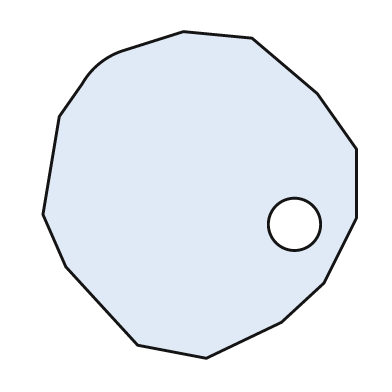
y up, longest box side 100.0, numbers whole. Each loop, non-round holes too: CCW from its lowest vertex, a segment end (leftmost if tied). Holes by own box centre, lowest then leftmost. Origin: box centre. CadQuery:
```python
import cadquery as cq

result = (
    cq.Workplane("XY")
    .moveTo(2.0, -50.0)
    .lineTo(25.0, -39.0)
    .lineTo(38.0, -27.0)
    .lineTo(48.0, -7.0)
    .lineTo(48.0, 14.0)
    .lineTo(36.0, 31.0)
    .lineTo(16.0, 48.0)
    .lineTo(-5.0, 50.0)
    .lineTo(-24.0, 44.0)
    .threePointArc((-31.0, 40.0), (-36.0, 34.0))
    .lineTo(-43.0, 24.0)
    .lineTo(-48.0, -6.0)
    .lineTo(-41.0, -22.0)
    .lineTo(-19.0, -46.0)
    .close()
    .moveTo(29.0, -9.0)
    .circle(8.0)
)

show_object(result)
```